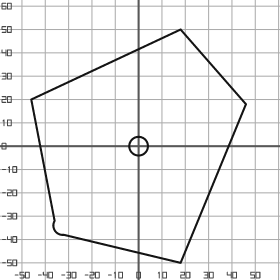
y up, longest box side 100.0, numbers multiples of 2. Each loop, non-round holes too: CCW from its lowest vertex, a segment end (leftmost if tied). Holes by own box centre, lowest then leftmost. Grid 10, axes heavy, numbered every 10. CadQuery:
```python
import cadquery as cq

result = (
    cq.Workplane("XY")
    .moveTo(18.0, -50.0)
    .lineTo(46.0, 18.0)
    .lineTo(18.0, 50.0)
    .lineTo(-46.0, 20.0)
    .lineTo(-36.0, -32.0)
    .threePointArc((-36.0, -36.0), (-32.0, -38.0))
    .close()
    .moveTo(0.0, 0.0)
    .circle(4.0)
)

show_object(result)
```